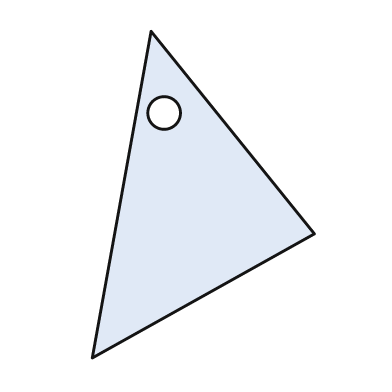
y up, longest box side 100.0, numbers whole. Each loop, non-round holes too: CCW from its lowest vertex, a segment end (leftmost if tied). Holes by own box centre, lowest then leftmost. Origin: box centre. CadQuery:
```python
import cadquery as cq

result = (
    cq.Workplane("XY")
    .moveTo(-34.0, -50.0)
    .lineTo(34.0, -12.0)
    .lineTo(-16.0, 50.0)
    .close()
    .moveTo(-12.0, 25.0)
    .circle(5.0)
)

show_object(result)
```